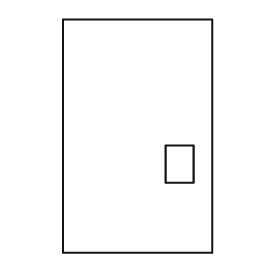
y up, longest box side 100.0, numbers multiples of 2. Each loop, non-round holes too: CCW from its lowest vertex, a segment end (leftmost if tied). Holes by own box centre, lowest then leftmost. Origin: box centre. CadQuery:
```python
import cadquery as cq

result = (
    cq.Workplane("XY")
    .moveTo(-32.0, -50.0)
    .lineTo(32.0, -50.0)
    .lineTo(32.0, 50.0)
    .lineTo(-32.0, 50.0)
    .close()
    .moveTo(12.0, -20.0)
    .lineTo(24.0, -20.0)
    .lineTo(24.0, -4.0)
    .lineTo(12.0, -4.0)
    .close()
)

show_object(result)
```